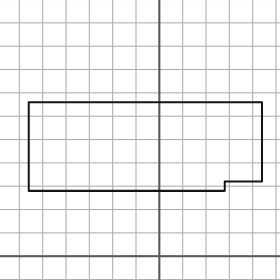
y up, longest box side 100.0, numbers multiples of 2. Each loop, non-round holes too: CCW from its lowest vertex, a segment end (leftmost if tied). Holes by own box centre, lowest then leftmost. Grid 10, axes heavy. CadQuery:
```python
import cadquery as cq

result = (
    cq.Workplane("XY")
    .moveTo(-56.0, 28.0)
    .lineTo(28.0, 28.0)
    .lineTo(28.0, 32.0)
    .lineTo(44.0, 32.0)
    .lineTo(44.0, 66.0)
    .lineTo(-56.0, 66.0)
    .close()
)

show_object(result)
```